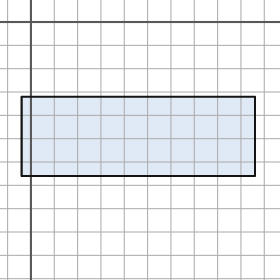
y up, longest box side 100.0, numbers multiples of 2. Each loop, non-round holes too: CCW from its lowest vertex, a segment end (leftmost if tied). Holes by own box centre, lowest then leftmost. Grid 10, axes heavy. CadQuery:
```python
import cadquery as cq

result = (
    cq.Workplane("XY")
    .moveTo(-4.0, -66.0)
    .lineTo(96.0, -66.0)
    .lineTo(96.0, -32.0)
    .lineTo(-4.0, -32.0)
    .close()
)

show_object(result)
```